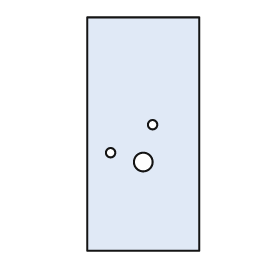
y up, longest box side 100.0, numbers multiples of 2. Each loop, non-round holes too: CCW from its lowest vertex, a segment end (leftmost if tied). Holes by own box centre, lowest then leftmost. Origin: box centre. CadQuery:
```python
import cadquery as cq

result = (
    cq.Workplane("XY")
    .moveTo(-24.0, -50.0)
    .lineTo(24.0, -50.0)
    .lineTo(24.0, 50.0)
    .lineTo(-24.0, 50.0)
    .close()
    .moveTo(0.0, -12.0)
    .circle(4.0)
    .moveTo(-14.0, -8.0)
    .circle(2.0)
    .moveTo(4.0, 4.0)
    .circle(2.0)
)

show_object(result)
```